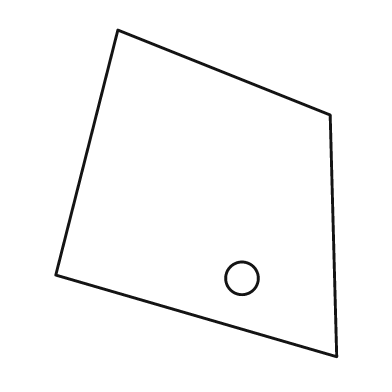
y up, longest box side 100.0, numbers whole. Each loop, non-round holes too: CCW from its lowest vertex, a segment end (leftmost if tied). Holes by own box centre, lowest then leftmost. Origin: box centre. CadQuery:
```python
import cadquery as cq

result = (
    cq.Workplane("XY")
    .moveTo(43.0, -50.0)
    .lineTo(41.0, 24.0)
    .lineTo(-24.0, 50.0)
    .lineTo(-43.0, -25.0)
    .close()
    .moveTo(14.0, -26.0)
    .circle(5.0)
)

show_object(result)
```